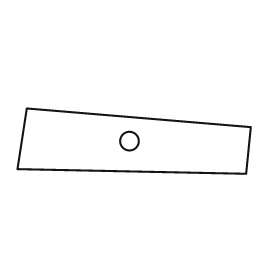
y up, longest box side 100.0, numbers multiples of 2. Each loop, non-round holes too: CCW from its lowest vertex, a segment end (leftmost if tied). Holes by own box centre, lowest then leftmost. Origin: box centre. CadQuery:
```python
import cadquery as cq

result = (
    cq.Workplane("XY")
    .moveTo(48.0, -14.0)
    .lineTo(50.0, 6.0)
    .lineTo(-46.0, 14.0)
    .lineTo(-50.0, -12.0)
    .close()
    .moveTo(-2.0, 0.0)
    .circle(4.0)
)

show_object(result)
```